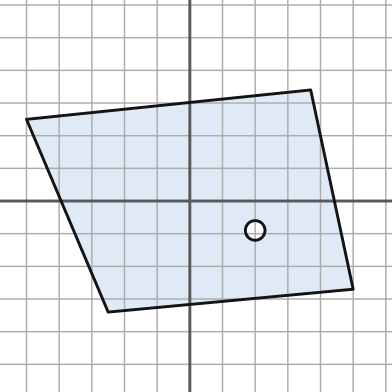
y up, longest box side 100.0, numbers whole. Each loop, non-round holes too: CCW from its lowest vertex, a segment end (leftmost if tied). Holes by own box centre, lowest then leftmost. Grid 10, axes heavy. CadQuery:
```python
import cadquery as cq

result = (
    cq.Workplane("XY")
    .moveTo(-25.0, -34.0)
    .lineTo(50.0, -27.0)
    .lineTo(37.0, 34.0)
    .lineTo(-50.0, 25.0)
    .close()
    .moveTo(20.0, -9.0)
    .circle(3.0)
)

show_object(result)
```